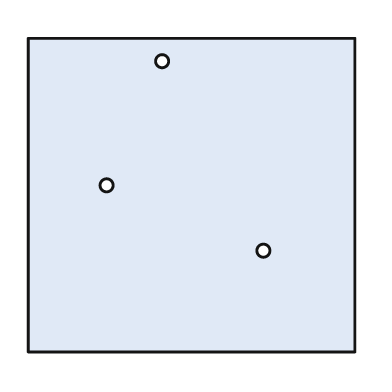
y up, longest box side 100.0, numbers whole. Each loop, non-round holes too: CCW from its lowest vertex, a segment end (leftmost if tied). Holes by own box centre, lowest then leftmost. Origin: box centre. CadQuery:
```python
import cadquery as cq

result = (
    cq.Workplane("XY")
    .moveTo(-50.0, -48.0)
    .lineTo(50.0, -48.0)
    .lineTo(50.0, 48.0)
    .lineTo(-50.0, 48.0)
    .close()
    .moveTo(22.0, -17.0)
    .circle(2.0)
    .moveTo(-26.0, 3.0)
    .circle(2.0)
    .moveTo(-9.0, 41.0)
    .circle(2.0)
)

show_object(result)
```